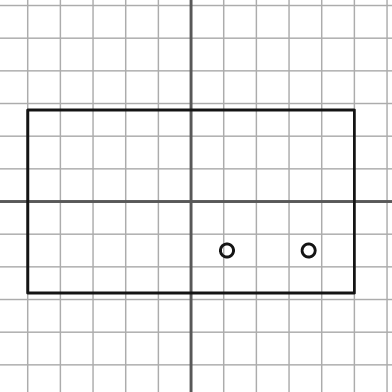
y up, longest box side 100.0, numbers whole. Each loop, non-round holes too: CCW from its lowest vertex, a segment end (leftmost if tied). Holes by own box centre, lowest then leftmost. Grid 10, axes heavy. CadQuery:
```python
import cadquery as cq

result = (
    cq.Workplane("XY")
    .moveTo(-50.0, -28.0)
    .lineTo(50.0, -28.0)
    .lineTo(50.0, 28.0)
    .lineTo(-50.0, 28.0)
    .close()
    .moveTo(11.0, -15.0)
    .circle(2.0)
    .moveTo(36.0, -15.0)
    .circle(2.0)
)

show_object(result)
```